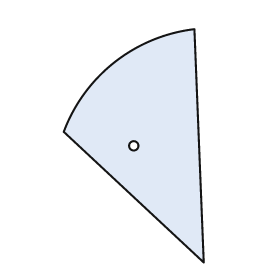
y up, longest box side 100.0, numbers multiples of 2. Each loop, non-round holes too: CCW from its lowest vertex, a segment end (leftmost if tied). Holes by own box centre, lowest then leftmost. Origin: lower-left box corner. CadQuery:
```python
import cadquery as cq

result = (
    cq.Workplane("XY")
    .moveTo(60.0, 0.0)
    .lineTo(56.0, 100.0)
    .threePointArc((22.0, 86.0), (0.0, 56.0))
    .close()
    .moveTo(30.0, 50.0)
    .circle(2.0)
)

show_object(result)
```